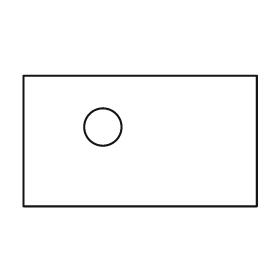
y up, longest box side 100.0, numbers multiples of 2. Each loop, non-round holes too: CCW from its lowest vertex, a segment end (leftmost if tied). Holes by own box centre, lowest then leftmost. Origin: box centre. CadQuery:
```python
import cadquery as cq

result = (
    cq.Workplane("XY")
    .moveTo(-50.0, -28.0)
    .lineTo(50.0, -28.0)
    .lineTo(50.0, 28.0)
    .lineTo(-50.0, 28.0)
    .close()
    .moveTo(-16.0, 6.0)
    .circle(8.0)
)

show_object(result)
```